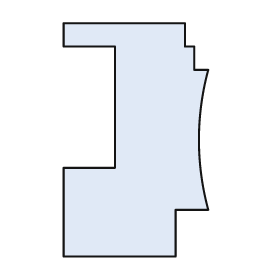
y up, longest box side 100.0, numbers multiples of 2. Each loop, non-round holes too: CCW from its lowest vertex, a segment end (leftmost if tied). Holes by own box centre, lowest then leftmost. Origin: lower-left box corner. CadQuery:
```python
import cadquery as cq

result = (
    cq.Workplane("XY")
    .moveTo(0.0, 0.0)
    .lineTo(48.0, 0.0)
    .lineTo(48.0, 20.0)
    .lineTo(62.0, 20.0)
    .threePointArc((58.0, 50.0), (62.0, 80.0))
    .lineTo(56.0, 80.0)
    .lineTo(56.0, 90.0)
    .lineTo(52.0, 90.0)
    .lineTo(52.0, 100.0)
    .lineTo(0.0, 100.0)
    .lineTo(0.0, 90.0)
    .lineTo(22.0, 90.0)
    .lineTo(22.0, 38.0)
    .lineTo(0.0, 38.0)
    .close()
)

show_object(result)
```